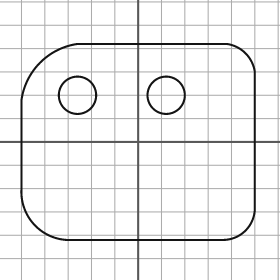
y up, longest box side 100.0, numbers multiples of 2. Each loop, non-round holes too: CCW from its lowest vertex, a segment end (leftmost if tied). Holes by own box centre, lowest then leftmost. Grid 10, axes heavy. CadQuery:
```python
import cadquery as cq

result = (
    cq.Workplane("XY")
    .moveTo(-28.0, -42.0)
    .lineTo(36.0, -42.0)
    .threePointArc((46.0, -38.0), (50.0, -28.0))
    .lineTo(50.0, 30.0)
    .threePointArc((46.0, 38.0), (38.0, 42.0))
    .lineTo(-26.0, 42.0)
    .threePointArc((-42.0, 34.0), (-50.0, 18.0))
    .lineTo(-50.0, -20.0)
    .threePointArc((-44.0, -36.0), (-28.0, -42.0))
    .close()
    .moveTo(-26.0, 20.0)
    .circle(8.0)
    .moveTo(12.0, 20.0)
    .circle(8.0)
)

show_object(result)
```